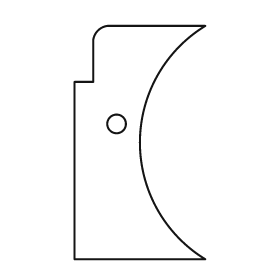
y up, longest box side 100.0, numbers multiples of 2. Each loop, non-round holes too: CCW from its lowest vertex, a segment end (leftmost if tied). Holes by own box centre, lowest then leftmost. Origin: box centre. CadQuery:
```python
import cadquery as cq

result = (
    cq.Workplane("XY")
    .moveTo(-28.0, -50.0)
    .lineTo(28.0, -50.0)
    .threePointArc((0.0, 0.0), (28.0, 50.0))
    .lineTo(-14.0, 50.0)
    .threePointArc((-18.0, 48.0), (-20.0, 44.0))
    .lineTo(-20.0, 26.0)
    .lineTo(-28.0, 26.0)
    .close()
    .moveTo(-10.0, 8.0)
    .circle(4.0)
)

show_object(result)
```